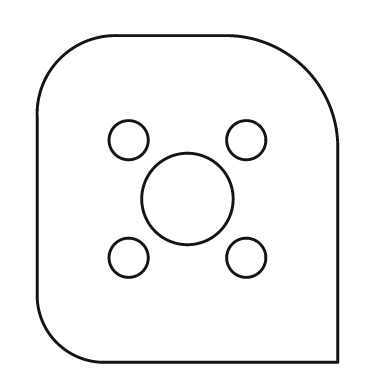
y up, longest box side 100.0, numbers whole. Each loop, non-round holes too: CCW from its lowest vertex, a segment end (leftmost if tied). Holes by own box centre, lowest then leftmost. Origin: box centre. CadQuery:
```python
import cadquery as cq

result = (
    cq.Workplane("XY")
    .moveTo(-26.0, -50.0)
    .lineTo(46.0, -50.0)
    .lineTo(46.0, 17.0)
    .threePointArc((36.0, 40.0), (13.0, 50.0))
    .lineTo(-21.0, 50.0)
    .threePointArc((-39.0, 43.0), (-46.0, 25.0))
    .lineTo(-46.0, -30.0)
    .threePointArc((-40.0, -44.0), (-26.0, -50.0))
    .close()
    .moveTo(-18.0, -18.0)
    .circle(6.0)
    .moveTo(18.0, -18.0)
    .circle(6.0)
    .moveTo(0.0, 0.0)
    .circle(14.0)
    .moveTo(-18.0, 18.0)
    .circle(6.0)
    .moveTo(18.0, 18.0)
    .circle(6.0)
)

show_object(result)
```